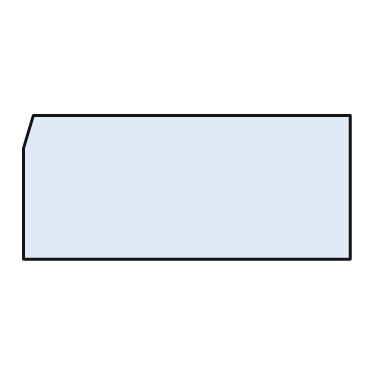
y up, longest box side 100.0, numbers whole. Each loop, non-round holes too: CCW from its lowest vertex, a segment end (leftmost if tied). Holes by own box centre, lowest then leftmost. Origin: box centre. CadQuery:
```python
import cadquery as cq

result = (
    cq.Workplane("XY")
    .moveTo(-50.0, -22.0)
    .lineTo(50.0, -22.0)
    .lineTo(50.0, 22.0)
    .lineTo(-47.0, 22.0)
    .lineTo(-50.0, 12.0)
    .close()
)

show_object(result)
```